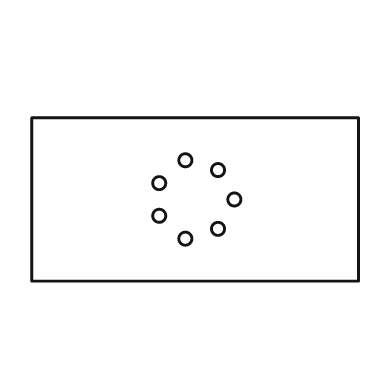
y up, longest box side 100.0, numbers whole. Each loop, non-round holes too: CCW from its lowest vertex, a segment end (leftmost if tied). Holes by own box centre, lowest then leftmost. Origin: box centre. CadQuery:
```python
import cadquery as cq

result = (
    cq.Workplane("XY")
    .moveTo(-50.0, -25.0)
    .lineTo(50.0, -25.0)
    .lineTo(50.0, 25.0)
    .lineTo(-50.0, 25.0)
    .close()
    .moveTo(-3.0, -12.0)
    .circle(2.0)
    .moveTo(7.0, -9.0)
    .circle(2.0)
    .moveTo(-11.0, -5.0)
    .circle(2.0)
    .moveTo(12.0, 0.0)
    .circle(2.0)
    .moveTo(-11.0, 5.0)
    .circle(2.0)
    .moveTo(7.0, 9.0)
    .circle(2.0)
    .moveTo(-3.0, 12.0)
    .circle(2.0)
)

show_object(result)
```